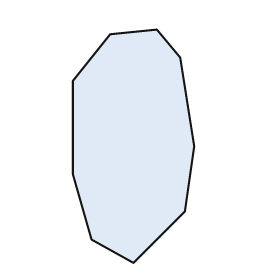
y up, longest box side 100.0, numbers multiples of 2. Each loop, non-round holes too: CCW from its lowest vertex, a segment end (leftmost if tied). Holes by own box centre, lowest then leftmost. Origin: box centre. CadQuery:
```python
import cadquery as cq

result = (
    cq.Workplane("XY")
    .moveTo(0.0, -50.0)
    .lineTo(22.0, -28.0)
    .lineTo(26.0, 0.0)
    .lineTo(20.0, 38.0)
    .lineTo(10.0, 50.0)
    .lineTo(-10.0, 48.0)
    .lineTo(-26.0, 28.0)
    .lineTo(-26.0, -12.0)
    .lineTo(-18.0, -40.0)
    .close()
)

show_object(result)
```